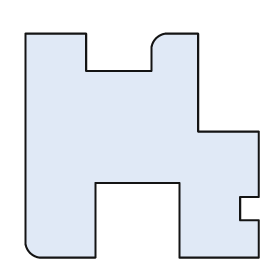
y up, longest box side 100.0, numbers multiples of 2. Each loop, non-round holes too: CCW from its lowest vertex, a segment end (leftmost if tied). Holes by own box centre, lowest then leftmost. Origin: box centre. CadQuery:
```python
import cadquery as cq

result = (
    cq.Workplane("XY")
    .moveTo(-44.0, -48.0)
    .lineTo(-20.0, -48.0)
    .lineTo(-20.0, -16.0)
    .lineTo(16.0, -16.0)
    .lineTo(16.0, -48.0)
    .lineTo(50.0, -48.0)
    .lineTo(50.0, -32.0)
    .lineTo(42.0, -32.0)
    .lineTo(42.0, -22.0)
    .lineTo(50.0, -22.0)
    .lineTo(50.0, 6.0)
    .lineTo(24.0, 6.0)
    .lineTo(24.0, 48.0)
    .lineTo(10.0, 48.0)
    .threePointArc((6.0, 46.0), (4.0, 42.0))
    .lineTo(4.0, 32.0)
    .lineTo(-24.0, 32.0)
    .lineTo(-24.0, 48.0)
    .lineTo(-50.0, 48.0)
    .lineTo(-50.0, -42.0)
    .threePointArc((-48.0, -46.0), (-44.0, -48.0))
    .close()
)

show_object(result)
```